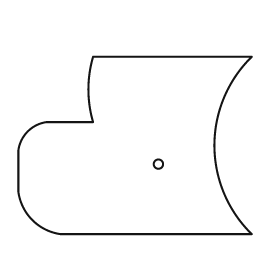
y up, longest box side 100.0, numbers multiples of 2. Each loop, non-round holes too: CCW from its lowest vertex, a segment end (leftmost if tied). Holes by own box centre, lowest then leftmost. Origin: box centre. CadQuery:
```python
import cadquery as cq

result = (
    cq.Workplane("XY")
    .moveTo(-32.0, -38.0)
    .lineTo(50.0, -38.0)
    .threePointArc((34.0, 0.0), (50.0, 38.0))
    .lineTo(-18.0, 38.0)
    .threePointArc((-20.0, 24.0), (-18.0, 10.0))
    .lineTo(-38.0, 10.0)
    .threePointArc((-46.0, 6.0), (-50.0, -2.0))
    .lineTo(-50.0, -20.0)
    .threePointArc((-44.0, -32.0), (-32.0, -38.0))
    .close()
    .moveTo(10.0, -8.0)
    .circle(2.0)
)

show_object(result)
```